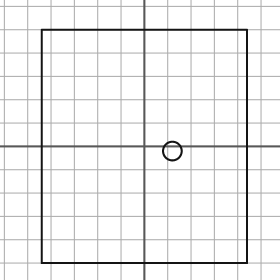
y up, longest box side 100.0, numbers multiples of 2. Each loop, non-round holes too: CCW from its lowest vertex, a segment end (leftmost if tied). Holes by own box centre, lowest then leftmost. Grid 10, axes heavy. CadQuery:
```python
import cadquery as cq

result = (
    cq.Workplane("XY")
    .moveTo(-44.0, -50.0)
    .lineTo(44.0, -50.0)
    .lineTo(44.0, 50.0)
    .lineTo(-44.0, 50.0)
    .close()
    .moveTo(12.0, -2.0)
    .circle(4.0)
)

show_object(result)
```